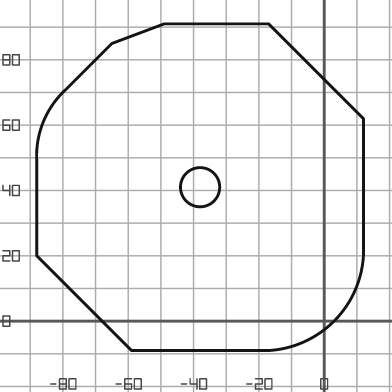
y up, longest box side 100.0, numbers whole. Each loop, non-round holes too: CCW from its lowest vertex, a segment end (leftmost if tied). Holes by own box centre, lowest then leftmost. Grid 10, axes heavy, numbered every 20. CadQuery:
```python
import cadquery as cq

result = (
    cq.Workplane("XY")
    .moveTo(-59.0, -9.0)
    .lineTo(-17.0, -9.0)
    .threePointArc((3.0, 0.0), (12.0, 20.0))
    .lineTo(12.0, 62.0)
    .lineTo(-17.0, 91.0)
    .lineTo(-49.0, 91.0)
    .lineTo(-65.0, 85.0)
    .lineTo(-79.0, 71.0)
    .threePointArc((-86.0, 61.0), (-88.0, 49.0))
    .lineTo(-88.0, 20.0)
    .close()
    .moveTo(-38.0, 41.0)
    .circle(6.0)
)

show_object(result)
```